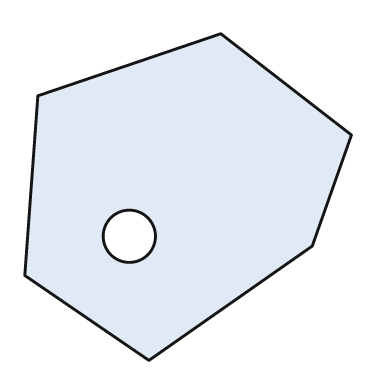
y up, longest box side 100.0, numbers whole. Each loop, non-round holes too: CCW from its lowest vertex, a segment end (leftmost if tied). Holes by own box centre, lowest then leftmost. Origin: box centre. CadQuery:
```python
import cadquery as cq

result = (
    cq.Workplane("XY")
    .moveTo(-12.0, -50.0)
    .lineTo(38.0, -15.0)
    .lineTo(50.0, 19.0)
    .lineTo(10.0, 50.0)
    .lineTo(-46.0, 31.0)
    .lineTo(-50.0, -24.0)
    .close()
    .moveTo(-18.0, -12.0)
    .circle(8.0)
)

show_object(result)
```